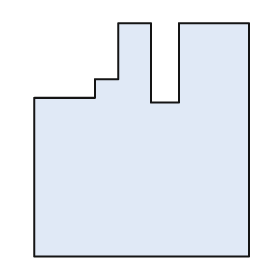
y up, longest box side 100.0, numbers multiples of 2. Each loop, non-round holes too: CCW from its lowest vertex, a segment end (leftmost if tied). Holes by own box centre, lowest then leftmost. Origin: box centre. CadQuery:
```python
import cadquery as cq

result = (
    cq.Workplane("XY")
    .moveTo(-46.0, -50.0)
    .lineTo(46.0, -50.0)
    .lineTo(46.0, 50.0)
    .lineTo(16.0, 50.0)
    .lineTo(16.0, 16.0)
    .lineTo(4.0, 16.0)
    .lineTo(4.0, 50.0)
    .lineTo(-10.0, 50.0)
    .lineTo(-10.0, 26.0)
    .lineTo(-20.0, 26.0)
    .lineTo(-20.0, 18.0)
    .lineTo(-46.0, 18.0)
    .close()
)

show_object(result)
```